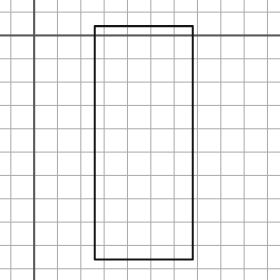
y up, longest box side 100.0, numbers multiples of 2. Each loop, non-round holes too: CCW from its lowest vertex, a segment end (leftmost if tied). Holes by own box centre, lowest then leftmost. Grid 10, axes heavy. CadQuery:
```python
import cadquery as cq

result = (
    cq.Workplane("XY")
    .moveTo(26.0, -96.0)
    .lineTo(68.0, -96.0)
    .lineTo(68.0, 4.0)
    .lineTo(26.0, 4.0)
    .close()
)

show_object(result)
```